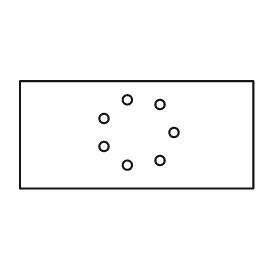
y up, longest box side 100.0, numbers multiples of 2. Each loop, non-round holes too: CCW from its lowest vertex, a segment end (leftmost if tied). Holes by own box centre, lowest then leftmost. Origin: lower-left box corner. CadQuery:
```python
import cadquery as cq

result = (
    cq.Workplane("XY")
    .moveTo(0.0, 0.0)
    .lineTo(100.0, 0.0)
    .lineTo(100.0, 46.0)
    .lineTo(0.0, 46.0)
    .close()
    .moveTo(46.0, 10.0)
    .circle(2.0)
    .moveTo(60.0, 12.0)
    .circle(2.0)
    .moveTo(36.0, 18.0)
    .circle(2.0)
    .moveTo(66.0, 24.0)
    .circle(2.0)
    .moveTo(36.0, 30.0)
    .circle(2.0)
    .moveTo(60.0, 36.0)
    .circle(2.0)
    .moveTo(46.0, 38.0)
    .circle(2.0)
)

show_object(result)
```